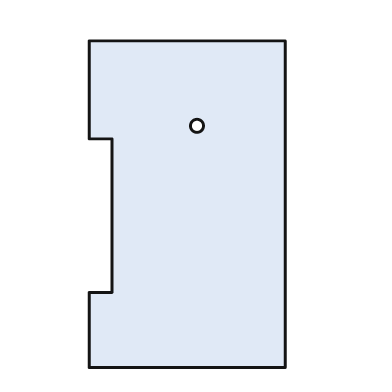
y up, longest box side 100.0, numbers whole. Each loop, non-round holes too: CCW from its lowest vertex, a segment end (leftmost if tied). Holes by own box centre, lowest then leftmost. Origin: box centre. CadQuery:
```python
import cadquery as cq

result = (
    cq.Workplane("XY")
    .moveTo(-30.0, -50.0)
    .lineTo(30.0, -50.0)
    .lineTo(30.0, 50.0)
    .lineTo(-30.0, 50.0)
    .lineTo(-30.0, 20.0)
    .lineTo(-23.0, 20.0)
    .lineTo(-23.0, -27.0)
    .lineTo(-30.0, -27.0)
    .close()
    .moveTo(3.0, 24.0)
    .circle(2.0)
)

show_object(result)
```